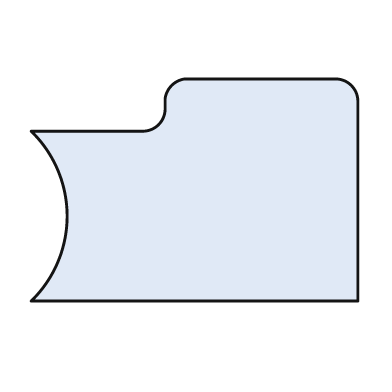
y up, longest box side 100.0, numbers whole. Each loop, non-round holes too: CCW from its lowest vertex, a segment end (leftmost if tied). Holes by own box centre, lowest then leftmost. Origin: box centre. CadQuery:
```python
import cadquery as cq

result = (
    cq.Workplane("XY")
    .moveTo(-50.0, -34.0)
    .lineTo(50.0, -34.0)
    .lineTo(50.0, 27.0)
    .threePointArc((48.0, 32.0), (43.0, 34.0))
    .lineTo(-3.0, 34.0)
    .threePointArc((-7.0, 32.0), (-9.0, 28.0))
    .lineTo(-9.0, 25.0)
    .threePointArc((-11.0, 20.0), (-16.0, 18.0))
    .lineTo(-50.0, 18.0)
    .threePointArc((-39.0, -8.0), (-50.0, -34.0))
    .close()
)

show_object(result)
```